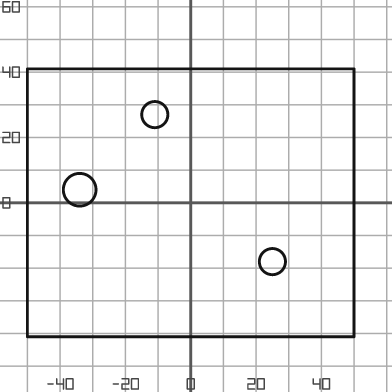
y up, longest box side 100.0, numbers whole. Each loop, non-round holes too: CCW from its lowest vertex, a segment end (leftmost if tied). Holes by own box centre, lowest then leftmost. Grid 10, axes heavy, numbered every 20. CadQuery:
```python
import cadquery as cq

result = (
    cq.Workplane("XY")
    .moveTo(-50.0, -41.0)
    .lineTo(50.0, -41.0)
    .lineTo(50.0, 41.0)
    .lineTo(-50.0, 41.0)
    .close()
    .moveTo(25.0, -18.0)
    .circle(4.0)
    .moveTo(-34.0, 4.0)
    .circle(5.0)
    .moveTo(-11.0, 27.0)
    .circle(4.0)
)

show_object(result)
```